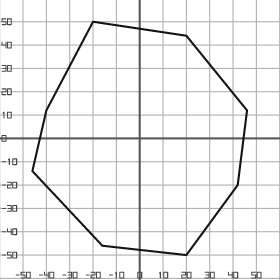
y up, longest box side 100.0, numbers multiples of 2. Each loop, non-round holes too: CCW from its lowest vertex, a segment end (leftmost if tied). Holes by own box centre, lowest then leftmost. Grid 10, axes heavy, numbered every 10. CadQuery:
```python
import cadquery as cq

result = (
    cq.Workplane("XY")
    .moveTo(20.0, -50.0)
    .lineTo(42.0, -20.0)
    .lineTo(46.0, 12.0)
    .lineTo(20.0, 44.0)
    .lineTo(-20.0, 50.0)
    .lineTo(-40.0, 12.0)
    .lineTo(-46.0, -14.0)
    .lineTo(-16.0, -46.0)
    .close()
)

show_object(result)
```